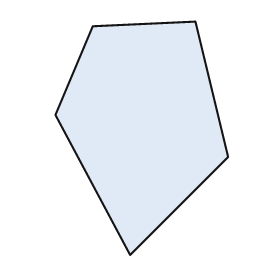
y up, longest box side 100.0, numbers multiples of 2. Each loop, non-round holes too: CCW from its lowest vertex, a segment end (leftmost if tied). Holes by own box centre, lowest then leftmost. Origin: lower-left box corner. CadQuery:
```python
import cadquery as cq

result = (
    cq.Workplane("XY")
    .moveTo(32.0, 0.0)
    .lineTo(74.0, 42.0)
    .lineTo(60.0, 100.0)
    .lineTo(16.0, 98.0)
    .lineTo(0.0, 60.0)
    .close()
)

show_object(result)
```